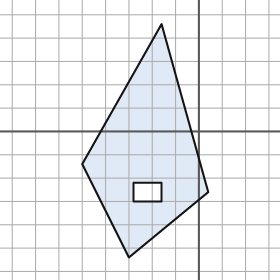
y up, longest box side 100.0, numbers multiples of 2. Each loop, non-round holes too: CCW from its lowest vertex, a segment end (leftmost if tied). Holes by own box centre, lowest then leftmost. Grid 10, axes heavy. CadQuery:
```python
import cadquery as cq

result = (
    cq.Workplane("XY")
    .moveTo(-30.0, -54.0)
    .lineTo(4.0, -26.0)
    .lineTo(-16.0, 46.0)
    .lineTo(-50.0, -14.0)
    .close()
    .moveTo(-28.0, -30.0)
    .lineTo(-16.0, -30.0)
    .lineTo(-16.0, -22.0)
    .lineTo(-28.0, -22.0)
    .close()
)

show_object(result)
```